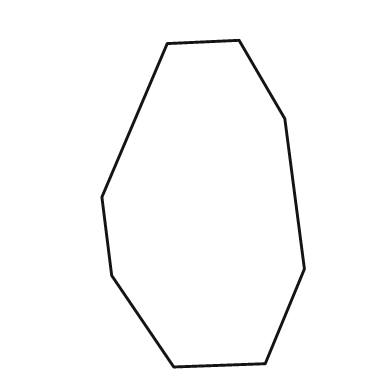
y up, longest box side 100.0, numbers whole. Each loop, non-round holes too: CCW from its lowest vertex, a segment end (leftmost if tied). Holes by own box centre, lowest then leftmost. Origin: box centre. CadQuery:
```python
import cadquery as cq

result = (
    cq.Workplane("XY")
    .moveTo(-9.0, -50.0)
    .lineTo(19.0, -49.0)
    .lineTo(31.0, -20.0)
    .lineTo(25.0, 26.0)
    .lineTo(11.0, 50.0)
    .lineTo(-11.0, 49.0)
    .lineTo(-31.0, 2.0)
    .lineTo(-28.0, -22.0)
    .close()
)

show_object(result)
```